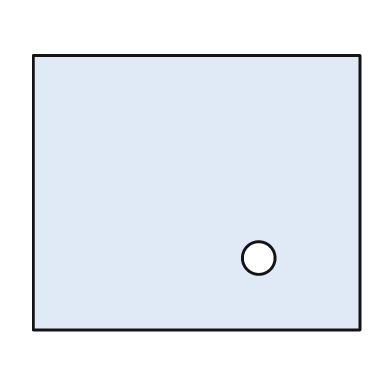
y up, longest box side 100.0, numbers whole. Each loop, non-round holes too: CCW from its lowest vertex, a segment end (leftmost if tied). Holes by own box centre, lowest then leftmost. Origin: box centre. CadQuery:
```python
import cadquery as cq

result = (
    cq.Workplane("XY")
    .moveTo(-50.0, -42.0)
    .lineTo(50.0, -42.0)
    .lineTo(50.0, 42.0)
    .lineTo(-50.0, 42.0)
    .close()
    .moveTo(19.0, -20.0)
    .circle(5.0)
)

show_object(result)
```